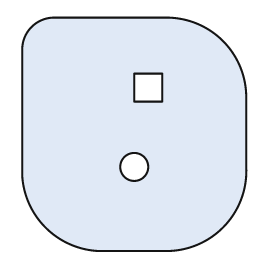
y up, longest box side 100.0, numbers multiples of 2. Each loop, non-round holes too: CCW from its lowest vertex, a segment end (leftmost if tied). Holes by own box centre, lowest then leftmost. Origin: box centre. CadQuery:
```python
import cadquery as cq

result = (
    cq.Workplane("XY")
    .moveTo(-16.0, -50.0)
    .lineTo(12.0, -50.0)
    .threePointArc((38.0, -40.0), (48.0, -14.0))
    .lineTo(48.0, 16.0)
    .threePointArc((38.0, 40.0), (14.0, 50.0))
    .lineTo(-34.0, 50.0)
    .threePointArc((-44.0, 46.0), (-48.0, 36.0))
    .lineTo(-48.0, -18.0)
    .threePointArc((-38.0, -40.0), (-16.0, -50.0))
    .close()
    .moveTo(0.0, -14.0)
    .circle(6.0)
    .moveTo(0.0, 14.0)
    .lineTo(12.0, 14.0)
    .lineTo(12.0, 26.0)
    .lineTo(0.0, 26.0)
    .close()
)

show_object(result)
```